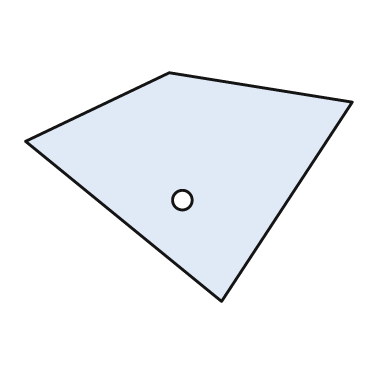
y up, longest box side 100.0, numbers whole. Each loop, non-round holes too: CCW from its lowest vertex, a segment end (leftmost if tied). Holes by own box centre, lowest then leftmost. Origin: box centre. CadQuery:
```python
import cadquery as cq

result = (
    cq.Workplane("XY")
    .moveTo(10.0, -35.0)
    .lineTo(50.0, 26.0)
    .lineTo(-6.0, 35.0)
    .lineTo(-50.0, 14.0)
    .close()
    .moveTo(-2.0, -4.0)
    .circle(3.0)
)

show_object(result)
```